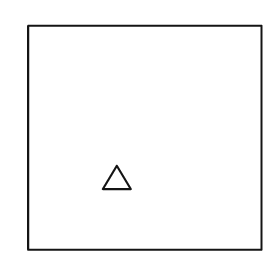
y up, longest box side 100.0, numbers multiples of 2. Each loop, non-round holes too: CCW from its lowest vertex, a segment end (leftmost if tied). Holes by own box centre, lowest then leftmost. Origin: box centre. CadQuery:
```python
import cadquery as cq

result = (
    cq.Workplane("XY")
    .moveTo(-50.0, -48.0)
    .lineTo(50.0, -48.0)
    .lineTo(50.0, 48.0)
    .lineTo(-50.0, 48.0)
    .close()
    .moveTo(-18.0, -22.0)
    .lineTo(-6.0, -22.0)
    .lineTo(-12.0, -12.0)
    .close()
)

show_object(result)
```